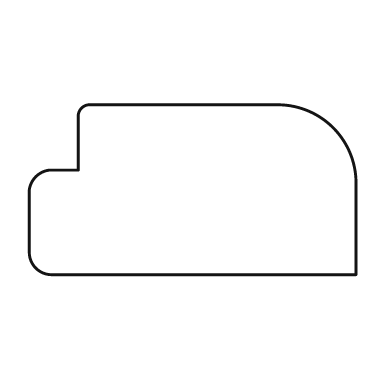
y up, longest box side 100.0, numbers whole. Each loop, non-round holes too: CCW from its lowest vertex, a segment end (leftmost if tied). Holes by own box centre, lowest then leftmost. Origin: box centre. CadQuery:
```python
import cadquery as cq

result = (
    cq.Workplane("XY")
    .moveTo(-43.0, -26.0)
    .lineTo(50.0, -26.0)
    .lineTo(50.0, 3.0)
    .threePointArc((43.0, 19.0), (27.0, 26.0))
    .lineTo(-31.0, 26.0)
    .threePointArc((-34.0, 25.0), (-35.0, 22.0))
    .lineTo(-35.0, 6.0)
    .lineTo(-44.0, 6.0)
    .threePointArc((-48.0, 4.0), (-50.0, 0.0))
    .lineTo(-50.0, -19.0)
    .threePointArc((-48.0, -24.0), (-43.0, -26.0))
    .close()
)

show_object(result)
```